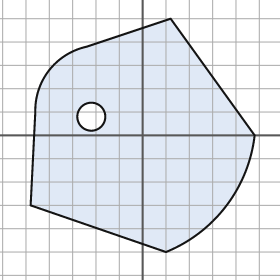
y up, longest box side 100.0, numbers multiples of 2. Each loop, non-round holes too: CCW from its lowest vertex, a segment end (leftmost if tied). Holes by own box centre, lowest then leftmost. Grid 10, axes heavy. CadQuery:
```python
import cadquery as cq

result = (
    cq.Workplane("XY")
    .moveTo(10.0, -50.0)
    .threePointArc((36.0, -30.0), (48.0, 0.0))
    .lineTo(12.0, 50.0)
    .lineTo(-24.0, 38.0)
    .threePointArc((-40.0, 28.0), (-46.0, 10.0))
    .lineTo(-48.0, -30.0)
    .close()
    .moveTo(-22.0, 8.0)
    .circle(6.0)
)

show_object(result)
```